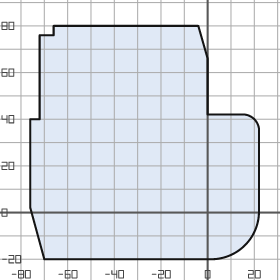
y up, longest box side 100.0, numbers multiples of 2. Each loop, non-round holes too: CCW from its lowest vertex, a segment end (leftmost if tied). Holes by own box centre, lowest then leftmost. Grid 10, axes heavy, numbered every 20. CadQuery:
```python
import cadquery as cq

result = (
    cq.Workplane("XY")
    .moveTo(-70.0, -20.0)
    .lineTo(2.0, -20.0)
    .threePointArc((16.0, -14.0), (22.0, 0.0))
    .lineTo(22.0, 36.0)
    .threePointArc((20.0, 40.0), (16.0, 42.0))
    .lineTo(0.0, 42.0)
    .lineTo(0.0, 66.0)
    .lineTo(-4.0, 80.0)
    .lineTo(-66.0, 80.0)
    .lineTo(-66.0, 76.0)
    .lineTo(-72.0, 76.0)
    .lineTo(-72.0, 40.0)
    .lineTo(-76.0, 40.0)
    .lineTo(-76.0, 2.0)
    .close()
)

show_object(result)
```